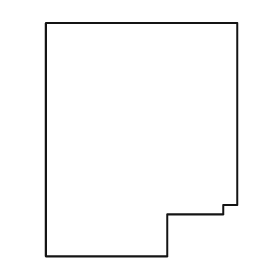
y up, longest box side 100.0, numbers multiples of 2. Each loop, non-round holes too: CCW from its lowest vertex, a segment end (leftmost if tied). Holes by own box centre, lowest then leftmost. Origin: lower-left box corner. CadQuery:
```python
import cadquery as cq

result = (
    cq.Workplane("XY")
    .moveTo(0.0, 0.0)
    .lineTo(52.0, 0.0)
    .lineTo(52.0, 18.0)
    .lineTo(76.0, 18.0)
    .lineTo(76.0, 22.0)
    .lineTo(82.0, 22.0)
    .lineTo(82.0, 100.0)
    .lineTo(0.0, 100.0)
    .close()
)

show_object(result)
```